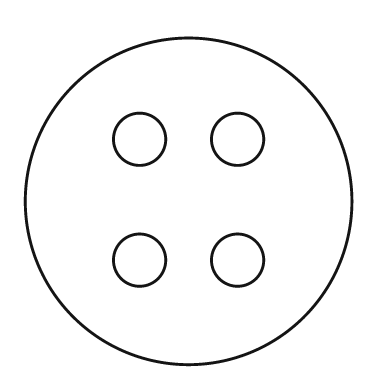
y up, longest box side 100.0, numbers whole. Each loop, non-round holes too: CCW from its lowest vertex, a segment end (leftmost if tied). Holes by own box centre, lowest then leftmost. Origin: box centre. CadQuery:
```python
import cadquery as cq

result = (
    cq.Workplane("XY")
    .moveTo(0.0, 0.0)
    .circle(50.0)
    .moveTo(-15.0, -18.0)
    .circle(8.0)
    .moveTo(15.0, -18.0)
    .circle(8.0)
    .moveTo(-15.0, 19.0)
    .circle(8.0)
    .moveTo(15.0, 19.0)
    .circle(8.0)
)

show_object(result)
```